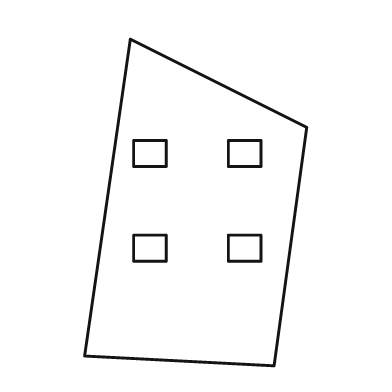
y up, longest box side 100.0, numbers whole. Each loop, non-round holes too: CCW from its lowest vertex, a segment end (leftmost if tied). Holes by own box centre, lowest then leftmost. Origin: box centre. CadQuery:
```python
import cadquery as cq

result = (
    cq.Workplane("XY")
    .moveTo(24.0, -50.0)
    .lineTo(34.0, 23.0)
    .lineTo(-20.0, 50.0)
    .lineTo(-34.0, -47.0)
    .close()
    .moveTo(-19.0, -18.0)
    .lineTo(-9.0, -18.0)
    .lineTo(-9.0, -10.0)
    .lineTo(-19.0, -10.0)
    .close()
    .moveTo(10.0, -18.0)
    .lineTo(20.0, -18.0)
    .lineTo(20.0, -10.0)
    .lineTo(10.0, -10.0)
    .close()
    .moveTo(-19.0, 11.0)
    .lineTo(-9.0, 11.0)
    .lineTo(-9.0, 19.0)
    .lineTo(-19.0, 19.0)
    .close()
    .moveTo(10.0, 11.0)
    .lineTo(20.0, 11.0)
    .lineTo(20.0, 19.0)
    .lineTo(10.0, 19.0)
    .close()
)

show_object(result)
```